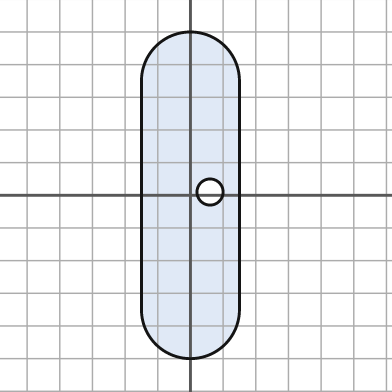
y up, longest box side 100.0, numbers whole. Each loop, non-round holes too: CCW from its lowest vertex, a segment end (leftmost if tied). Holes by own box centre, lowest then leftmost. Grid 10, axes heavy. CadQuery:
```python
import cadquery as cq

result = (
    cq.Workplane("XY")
    .moveTo(-15.0, -35.0)
    .threePointArc((0.0, -50.0), (15.0, -35.0))
    .lineTo(15.0, 35.0)
    .threePointArc((0.0, 50.0), (-15.0, 35.0))
    .close()
    .moveTo(6.0, 1.0)
    .circle(4.0)
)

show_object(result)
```